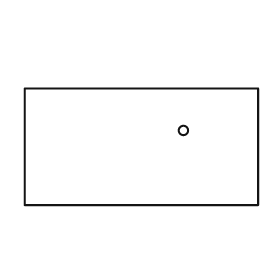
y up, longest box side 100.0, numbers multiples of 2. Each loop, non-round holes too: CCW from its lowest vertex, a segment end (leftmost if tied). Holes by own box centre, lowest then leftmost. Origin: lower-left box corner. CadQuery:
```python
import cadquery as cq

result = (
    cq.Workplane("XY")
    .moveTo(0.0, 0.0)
    .lineTo(100.0, 0.0)
    .lineTo(100.0, 50.0)
    .lineTo(0.0, 50.0)
    .close()
    .moveTo(68.0, 32.0)
    .circle(2.0)
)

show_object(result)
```